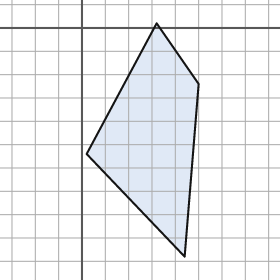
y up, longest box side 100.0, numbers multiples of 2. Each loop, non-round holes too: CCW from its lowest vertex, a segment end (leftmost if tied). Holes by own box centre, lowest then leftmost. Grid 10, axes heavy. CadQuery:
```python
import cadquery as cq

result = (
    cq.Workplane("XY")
    .moveTo(44.0, -98.0)
    .lineTo(50.0, -24.0)
    .lineTo(32.0, 2.0)
    .lineTo(2.0, -54.0)
    .close()
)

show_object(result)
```